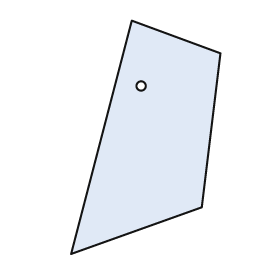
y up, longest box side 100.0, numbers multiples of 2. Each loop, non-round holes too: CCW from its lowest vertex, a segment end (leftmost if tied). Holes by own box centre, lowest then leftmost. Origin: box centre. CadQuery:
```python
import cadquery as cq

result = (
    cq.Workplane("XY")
    .moveTo(-32.0, -50.0)
    .lineTo(24.0, -30.0)
    .lineTo(32.0, 36.0)
    .lineTo(-6.0, 50.0)
    .close()
    .moveTo(-2.0, 22.0)
    .circle(2.0)
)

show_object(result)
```